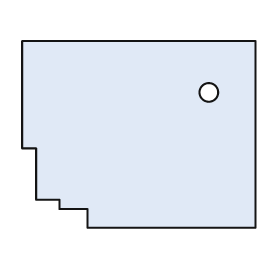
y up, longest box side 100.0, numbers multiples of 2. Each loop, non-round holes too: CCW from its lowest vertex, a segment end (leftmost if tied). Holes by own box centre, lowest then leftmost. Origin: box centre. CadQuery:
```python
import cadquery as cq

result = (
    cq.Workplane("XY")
    .moveTo(-22.0, -40.0)
    .lineTo(50.0, -40.0)
    .lineTo(50.0, 40.0)
    .lineTo(-50.0, 40.0)
    .lineTo(-50.0, -6.0)
    .lineTo(-44.0, -6.0)
    .lineTo(-44.0, -28.0)
    .lineTo(-34.0, -28.0)
    .lineTo(-34.0, -32.0)
    .lineTo(-22.0, -32.0)
    .close()
    .moveTo(30.0, 18.0)
    .circle(4.0)
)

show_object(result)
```